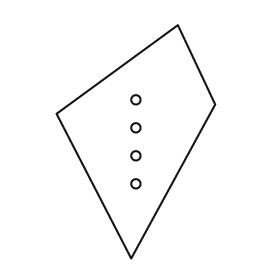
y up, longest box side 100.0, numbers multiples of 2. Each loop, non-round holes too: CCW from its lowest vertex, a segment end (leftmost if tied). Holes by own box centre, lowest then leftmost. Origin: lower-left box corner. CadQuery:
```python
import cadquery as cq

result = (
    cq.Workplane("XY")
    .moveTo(32.0, 0.0)
    .lineTo(68.0, 66.0)
    .lineTo(52.0, 100.0)
    .lineTo(0.0, 62.0)
    .close()
    .moveTo(34.0, 32.0)
    .circle(2.0)
    .moveTo(34.0, 44.0)
    .circle(2.0)
    .moveTo(34.0, 56.0)
    .circle(2.0)
    .moveTo(34.0, 68.0)
    .circle(2.0)
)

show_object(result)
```